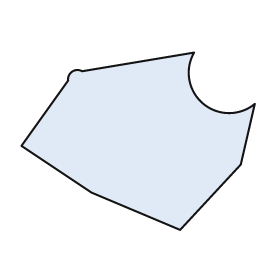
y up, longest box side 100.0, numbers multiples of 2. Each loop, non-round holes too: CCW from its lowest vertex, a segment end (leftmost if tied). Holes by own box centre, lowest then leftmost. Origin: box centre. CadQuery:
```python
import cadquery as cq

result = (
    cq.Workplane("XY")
    .moveTo(18.0, -38.0)
    .lineTo(44.0, -10.0)
    .lineTo(50.0, 16.0)
    .threePointArc((28.0, 16.0), (24.0, 38.0))
    .lineTo(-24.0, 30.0)
    .threePointArc((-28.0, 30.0), (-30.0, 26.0))
    .lineTo(-50.0, -2.0)
    .lineTo(-20.0, -22.0)
    .close()
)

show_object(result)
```